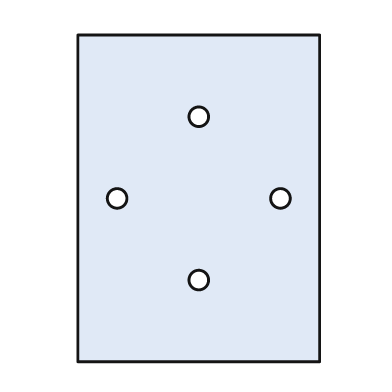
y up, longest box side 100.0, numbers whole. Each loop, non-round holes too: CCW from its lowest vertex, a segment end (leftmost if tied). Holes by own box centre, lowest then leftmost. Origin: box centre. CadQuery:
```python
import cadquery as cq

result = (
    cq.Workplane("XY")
    .moveTo(-37.0, -50.0)
    .lineTo(37.0, -50.0)
    .lineTo(37.0, 50.0)
    .lineTo(-37.0, 50.0)
    .close()
    .moveTo(0.0, -25.0)
    .circle(3.0)
    .moveTo(-25.0, 0.0)
    .circle(3.0)
    .moveTo(25.0, 0.0)
    .circle(3.0)
    .moveTo(0.0, 25.0)
    .circle(3.0)
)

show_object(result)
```